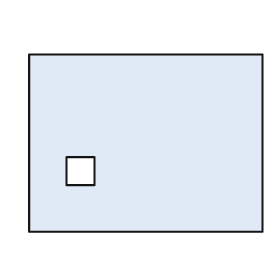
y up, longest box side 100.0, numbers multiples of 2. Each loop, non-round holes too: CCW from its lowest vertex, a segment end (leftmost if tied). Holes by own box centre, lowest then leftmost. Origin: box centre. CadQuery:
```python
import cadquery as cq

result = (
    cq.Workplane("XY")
    .moveTo(-50.0, -38.0)
    .lineTo(50.0, -38.0)
    .lineTo(50.0, 38.0)
    .lineTo(-50.0, 38.0)
    .close()
    .moveTo(-34.0, -18.0)
    .lineTo(-22.0, -18.0)
    .lineTo(-22.0, -6.0)
    .lineTo(-34.0, -6.0)
    .close()
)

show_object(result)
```